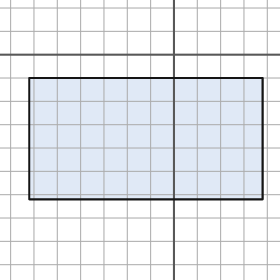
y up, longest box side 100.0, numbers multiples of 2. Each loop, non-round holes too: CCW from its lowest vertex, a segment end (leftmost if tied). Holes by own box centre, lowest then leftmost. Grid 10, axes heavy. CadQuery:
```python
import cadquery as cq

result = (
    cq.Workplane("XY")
    .moveTo(-62.0, -62.0)
    .lineTo(38.0, -62.0)
    .lineTo(38.0, -10.0)
    .lineTo(-62.0, -10.0)
    .close()
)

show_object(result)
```